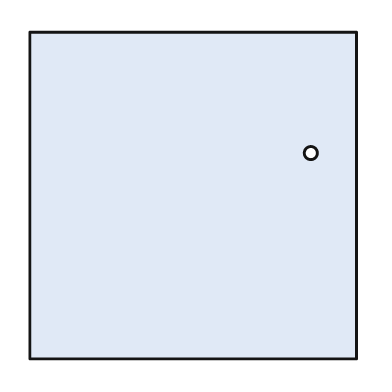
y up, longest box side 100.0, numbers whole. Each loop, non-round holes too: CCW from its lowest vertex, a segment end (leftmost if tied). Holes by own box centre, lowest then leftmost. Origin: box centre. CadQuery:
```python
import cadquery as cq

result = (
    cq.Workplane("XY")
    .moveTo(-50.0, -50.0)
    .lineTo(50.0, -50.0)
    .lineTo(50.0, 50.0)
    .lineTo(-50.0, 50.0)
    .close()
    .moveTo(36.0, 13.0)
    .circle(2.0)
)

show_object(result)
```